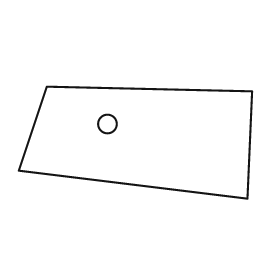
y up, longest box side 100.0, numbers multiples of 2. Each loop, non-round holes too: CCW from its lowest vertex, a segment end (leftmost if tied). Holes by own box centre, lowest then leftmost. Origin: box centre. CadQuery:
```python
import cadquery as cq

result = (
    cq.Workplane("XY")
    .moveTo(48.0, -24.0)
    .lineTo(50.0, 22.0)
    .lineTo(-38.0, 24.0)
    .lineTo(-50.0, -12.0)
    .close()
    .moveTo(-12.0, 8.0)
    .circle(4.0)
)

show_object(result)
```